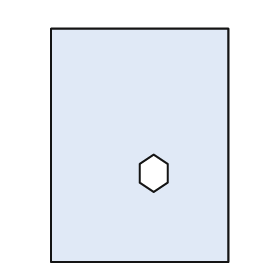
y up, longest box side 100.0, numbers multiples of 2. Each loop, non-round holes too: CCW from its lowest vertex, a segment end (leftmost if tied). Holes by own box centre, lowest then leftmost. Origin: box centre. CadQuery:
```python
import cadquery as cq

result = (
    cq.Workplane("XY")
    .moveTo(-38.0, -50.0)
    .lineTo(38.0, -50.0)
    .lineTo(38.0, 50.0)
    .lineTo(-38.0, 50.0)
    .close()
    .moveTo(6.0, -20.0)
    .lineTo(12.0, -16.0)
    .lineTo(12.0, -8.0)
    .lineTo(6.0, -4.0)
    .lineTo(0.0, -8.0)
    .lineTo(0.0, -16.0)
    .close()
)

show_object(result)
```